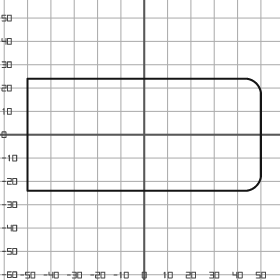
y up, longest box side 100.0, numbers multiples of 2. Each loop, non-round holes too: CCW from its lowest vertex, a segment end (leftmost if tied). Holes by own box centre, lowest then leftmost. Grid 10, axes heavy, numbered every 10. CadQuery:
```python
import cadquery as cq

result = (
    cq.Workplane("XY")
    .moveTo(-50.0, -24.0)
    .lineTo(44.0, -24.0)
    .threePointArc((48.0, -22.0), (50.0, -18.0))
    .lineTo(50.0, 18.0)
    .threePointArc((48.0, 22.0), (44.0, 24.0))
    .lineTo(-50.0, 24.0)
    .close()
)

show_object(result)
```